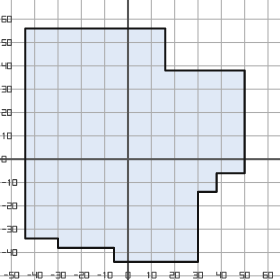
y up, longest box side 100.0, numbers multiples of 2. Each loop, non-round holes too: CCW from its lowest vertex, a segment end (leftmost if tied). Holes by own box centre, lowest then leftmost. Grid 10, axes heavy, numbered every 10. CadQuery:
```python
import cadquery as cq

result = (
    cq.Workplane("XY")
    .moveTo(-6.0, -44.0)
    .lineTo(30.0, -44.0)
    .lineTo(30.0, -14.0)
    .lineTo(38.0, -14.0)
    .lineTo(38.0, -6.0)
    .lineTo(50.0, -6.0)
    .lineTo(50.0, 38.0)
    .lineTo(16.0, 38.0)
    .lineTo(16.0, 56.0)
    .lineTo(-44.0, 56.0)
    .lineTo(-44.0, -34.0)
    .lineTo(-30.0, -34.0)
    .lineTo(-30.0, -38.0)
    .lineTo(-6.0, -38.0)
    .close()
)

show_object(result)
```